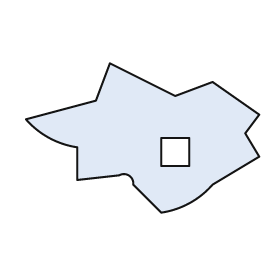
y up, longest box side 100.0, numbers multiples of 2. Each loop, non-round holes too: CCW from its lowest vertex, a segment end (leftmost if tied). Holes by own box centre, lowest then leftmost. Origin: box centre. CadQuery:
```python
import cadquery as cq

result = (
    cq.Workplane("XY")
    .moveTo(8.0, -32.0)
    .threePointArc((20.0, -28.0), (30.0, -20.0))
    .lineTo(50.0, -8.0)
    .lineTo(44.0, 2.0)
    .lineTo(50.0, 10.0)
    .lineTo(30.0, 24.0)
    .lineTo(14.0, 18.0)
    .lineTo(-14.0, 32.0)
    .lineTo(-20.0, 16.0)
    .lineTo(-50.0, 8.0)
    .threePointArc((-40.0, 0.0), (-28.0, -4.0))
    .lineTo(-28.0, -18.0)
    .lineTo(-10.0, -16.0)
    .threePointArc((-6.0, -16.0), (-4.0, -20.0))
    .close()
    .moveTo(8.0, -12.0)
    .lineTo(20.0, -12.0)
    .lineTo(20.0, 0.0)
    .lineTo(8.0, 0.0)
    .close()
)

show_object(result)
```